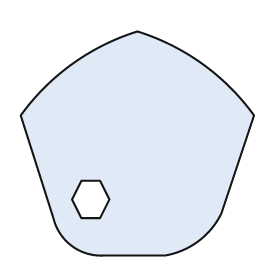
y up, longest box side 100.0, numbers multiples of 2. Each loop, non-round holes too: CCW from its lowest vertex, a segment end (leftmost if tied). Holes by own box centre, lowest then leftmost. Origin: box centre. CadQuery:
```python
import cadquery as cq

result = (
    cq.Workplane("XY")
    .moveTo(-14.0, -48.0)
    .lineTo(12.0, -48.0)
    .threePointArc((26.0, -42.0), (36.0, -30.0))
    .lineTo(50.0, 12.0)
    .threePointArc((28.0, 34.0), (0.0, 48.0))
    .threePointArc((-28.0, 34.0), (-50.0, 12.0))
    .lineTo(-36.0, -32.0)
    .threePointArc((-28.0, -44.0), (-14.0, -48.0))
    .close()
    .moveTo(-24.0, -32.0)
    .lineTo(-16.0, -32.0)
    .lineTo(-12.0, -24.0)
    .lineTo(-16.0, -16.0)
    .lineTo(-24.0, -16.0)
    .lineTo(-28.0, -24.0)
    .close()
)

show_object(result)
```